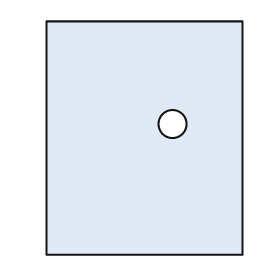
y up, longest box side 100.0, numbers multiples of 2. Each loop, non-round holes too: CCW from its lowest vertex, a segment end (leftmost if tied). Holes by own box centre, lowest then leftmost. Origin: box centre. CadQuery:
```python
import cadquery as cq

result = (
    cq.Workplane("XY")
    .moveTo(-42.0, -50.0)
    .lineTo(42.0, -50.0)
    .lineTo(42.0, 50.0)
    .lineTo(-42.0, 50.0)
    .close()
    .moveTo(12.0, 6.0)
    .circle(6.0)
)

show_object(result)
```